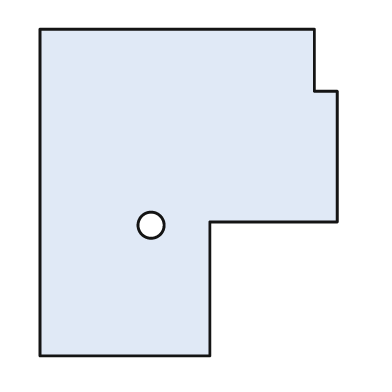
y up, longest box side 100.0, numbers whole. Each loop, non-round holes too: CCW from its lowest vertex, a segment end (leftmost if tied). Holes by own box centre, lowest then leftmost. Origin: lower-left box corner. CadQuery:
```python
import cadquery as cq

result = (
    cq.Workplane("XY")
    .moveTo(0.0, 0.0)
    .lineTo(52.0, 0.0)
    .lineTo(52.0, 41.0)
    .lineTo(91.0, 41.0)
    .lineTo(91.0, 81.0)
    .lineTo(84.0, 81.0)
    .lineTo(84.0, 100.0)
    .lineTo(0.0, 100.0)
    .close()
    .moveTo(34.0, 40.0)
    .circle(4.0)
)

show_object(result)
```